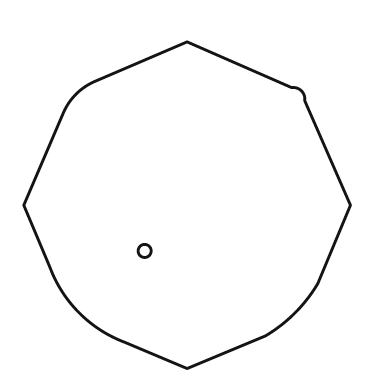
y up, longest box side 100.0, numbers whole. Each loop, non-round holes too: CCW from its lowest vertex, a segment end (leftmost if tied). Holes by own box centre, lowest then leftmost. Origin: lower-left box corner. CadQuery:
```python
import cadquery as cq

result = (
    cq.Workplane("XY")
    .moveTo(50.0, 0.0)
    .lineTo(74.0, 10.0)
    .threePointArc((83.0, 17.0), (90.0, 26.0))
    .lineTo(100.0, 50.0)
    .lineTo(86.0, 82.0)
    .threePointArc((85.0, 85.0), (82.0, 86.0))
    .lineTo(50.0, 100.0)
    .lineTo(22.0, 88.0)
    .threePointArc((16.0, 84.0), (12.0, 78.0))
    .lineTo(0.0, 50.0)
    .lineTo(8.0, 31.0)
    .threePointArc((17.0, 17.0), (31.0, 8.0))
    .close()
    .moveTo(37.0, 36.0)
    .circle(2.0)
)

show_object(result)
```